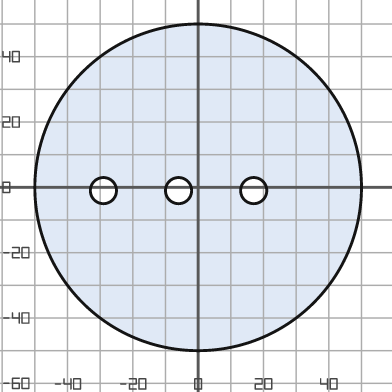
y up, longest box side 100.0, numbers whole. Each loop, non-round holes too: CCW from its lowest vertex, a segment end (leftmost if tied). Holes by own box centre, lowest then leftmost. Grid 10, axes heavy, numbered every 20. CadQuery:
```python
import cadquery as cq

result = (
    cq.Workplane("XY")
    .moveTo(0.0, 0.0)
    .circle(50.0)
    .moveTo(-29.0, -1.0)
    .circle(4.0)
    .moveTo(-6.0, -1.0)
    .circle(4.0)
    .moveTo(17.0, -1.0)
    .circle(4.0)
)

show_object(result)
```